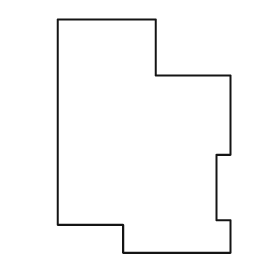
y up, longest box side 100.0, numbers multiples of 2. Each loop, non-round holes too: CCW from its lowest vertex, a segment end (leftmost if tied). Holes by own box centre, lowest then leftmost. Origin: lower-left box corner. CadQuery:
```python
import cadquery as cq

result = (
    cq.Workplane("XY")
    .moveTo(28.0, 0.0)
    .lineTo(74.0, 0.0)
    .lineTo(74.0, 14.0)
    .lineTo(68.0, 14.0)
    .lineTo(68.0, 42.0)
    .lineTo(74.0, 42.0)
    .lineTo(74.0, 76.0)
    .lineTo(42.0, 76.0)
    .lineTo(42.0, 100.0)
    .lineTo(0.0, 100.0)
    .lineTo(0.0, 12.0)
    .lineTo(28.0, 12.0)
    .close()
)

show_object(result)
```